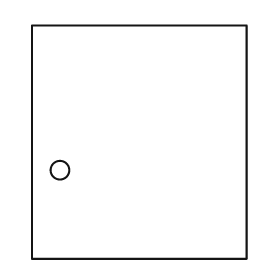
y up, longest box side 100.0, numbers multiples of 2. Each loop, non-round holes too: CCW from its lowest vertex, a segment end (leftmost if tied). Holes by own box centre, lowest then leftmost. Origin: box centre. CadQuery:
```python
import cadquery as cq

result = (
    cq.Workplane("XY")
    .moveTo(-46.0, -50.0)
    .lineTo(46.0, -50.0)
    .lineTo(46.0, 50.0)
    .lineTo(-46.0, 50.0)
    .close()
    .moveTo(-34.0, -12.0)
    .circle(4.0)
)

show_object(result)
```